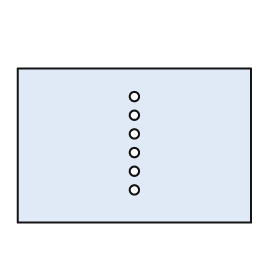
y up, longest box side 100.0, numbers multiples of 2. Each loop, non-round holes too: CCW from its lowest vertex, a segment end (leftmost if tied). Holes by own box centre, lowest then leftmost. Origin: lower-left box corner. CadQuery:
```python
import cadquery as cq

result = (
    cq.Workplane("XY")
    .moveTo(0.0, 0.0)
    .lineTo(100.0, 0.0)
    .lineTo(100.0, 66.0)
    .lineTo(0.0, 66.0)
    .close()
    .moveTo(50.0, 14.0)
    .circle(2.0)
    .moveTo(50.0, 22.0)
    .circle(2.0)
    .moveTo(50.0, 30.0)
    .circle(2.0)
    .moveTo(50.0, 38.0)
    .circle(2.0)
    .moveTo(50.0, 46.0)
    .circle(2.0)
    .moveTo(50.0, 54.0)
    .circle(2.0)
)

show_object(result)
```